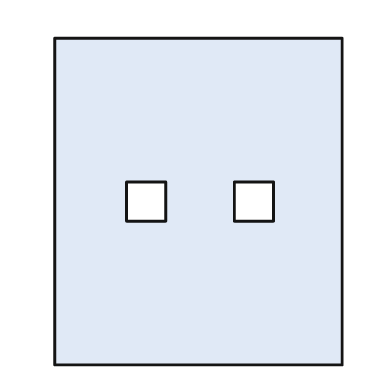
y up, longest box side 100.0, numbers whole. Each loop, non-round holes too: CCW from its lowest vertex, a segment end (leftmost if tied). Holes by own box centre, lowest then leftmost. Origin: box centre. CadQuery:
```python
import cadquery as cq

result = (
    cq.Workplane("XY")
    .moveTo(-44.0, -50.0)
    .lineTo(44.0, -50.0)
    .lineTo(44.0, 50.0)
    .lineTo(-44.0, 50.0)
    .close()
    .moveTo(-22.0, -6.0)
    .lineTo(-10.0, -6.0)
    .lineTo(-10.0, 6.0)
    .lineTo(-22.0, 6.0)
    .close()
    .moveTo(11.0, -6.0)
    .lineTo(23.0, -6.0)
    .lineTo(23.0, 6.0)
    .lineTo(11.0, 6.0)
    .close()
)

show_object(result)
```